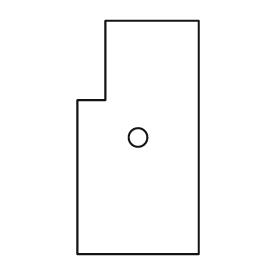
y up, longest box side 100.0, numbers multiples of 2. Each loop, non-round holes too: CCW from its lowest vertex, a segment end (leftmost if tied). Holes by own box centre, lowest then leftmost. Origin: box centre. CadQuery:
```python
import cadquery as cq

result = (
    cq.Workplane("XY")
    .moveTo(-26.0, -50.0)
    .lineTo(26.0, -50.0)
    .lineTo(26.0, 50.0)
    .lineTo(-14.0, 50.0)
    .lineTo(-14.0, 16.0)
    .lineTo(-26.0, 16.0)
    .close()
    .moveTo(0.0, 0.0)
    .circle(4.0)
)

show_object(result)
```